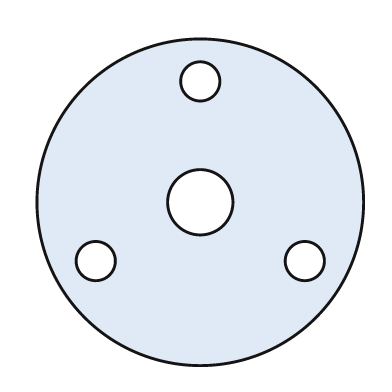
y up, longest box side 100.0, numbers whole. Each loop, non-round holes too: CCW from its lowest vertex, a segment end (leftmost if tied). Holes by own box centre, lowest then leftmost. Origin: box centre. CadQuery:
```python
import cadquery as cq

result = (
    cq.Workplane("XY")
    .moveTo(0.0, 0.0)
    .circle(50.0)
    .moveTo(-32.0, -18.0)
    .circle(6.0)
    .moveTo(32.0, -18.0)
    .circle(6.0)
    .moveTo(0.0, 0.0)
    .circle(10.0)
    .moveTo(0.0, 37.0)
    .circle(6.0)
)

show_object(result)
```